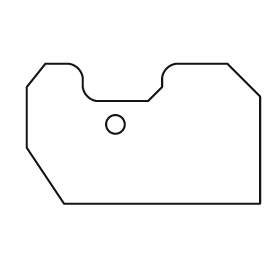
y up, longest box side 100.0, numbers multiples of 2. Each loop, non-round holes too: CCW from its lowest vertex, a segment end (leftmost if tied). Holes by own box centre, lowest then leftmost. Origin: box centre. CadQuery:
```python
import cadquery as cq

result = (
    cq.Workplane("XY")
    .moveTo(-34.0, -30.0)
    .lineTo(50.0, -30.0)
    .lineTo(50.0, 16.0)
    .lineTo(36.0, 30.0)
    .lineTo(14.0, 30.0)
    .threePointArc((10.0, 28.0), (8.0, 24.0))
    .lineTo(8.0, 20.0)
    .lineTo(2.0, 14.0)
    .lineTo(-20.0, 14.0)
    .threePointArc((-24.0, 16.0), (-26.0, 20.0))
    .lineTo(-26.0, 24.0)
    .threePointArc((-28.0, 28.0), (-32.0, 30.0))
    .lineTo(-42.0, 30.0)
    .lineTo(-50.0, 20.0)
    .lineTo(-50.0, -6.0)
    .close()
    .moveTo(-12.0, 4.0)
    .circle(4.0)
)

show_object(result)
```